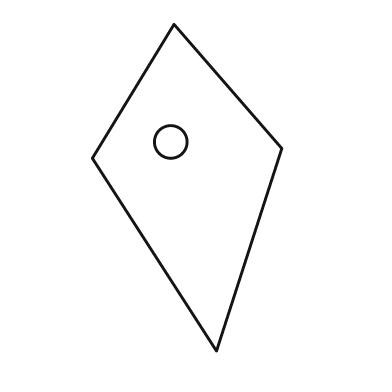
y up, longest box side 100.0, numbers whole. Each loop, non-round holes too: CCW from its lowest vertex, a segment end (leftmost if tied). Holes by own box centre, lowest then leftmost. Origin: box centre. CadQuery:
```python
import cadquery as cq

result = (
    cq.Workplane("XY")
    .moveTo(9.0, -50.0)
    .lineTo(29.0, 12.0)
    .lineTo(-4.0, 50.0)
    .lineTo(-29.0, 9.0)
    .close()
    .moveTo(-5.0, 14.0)
    .circle(5.0)
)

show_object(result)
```